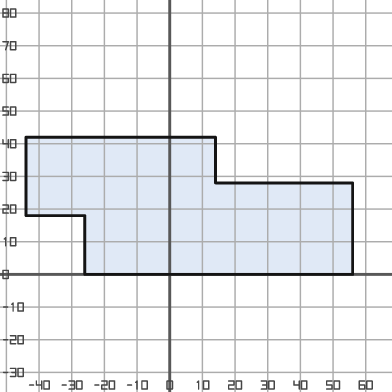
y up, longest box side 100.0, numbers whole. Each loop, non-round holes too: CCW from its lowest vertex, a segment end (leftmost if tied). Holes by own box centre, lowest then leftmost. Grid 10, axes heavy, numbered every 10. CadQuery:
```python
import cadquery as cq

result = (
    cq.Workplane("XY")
    .moveTo(-26.0, 0.0)
    .lineTo(56.0, 0.0)
    .lineTo(56.0, 28.0)
    .lineTo(14.0, 28.0)
    .lineTo(14.0, 42.0)
    .lineTo(-44.0, 42.0)
    .lineTo(-44.0, 18.0)
    .lineTo(-26.0, 18.0)
    .close()
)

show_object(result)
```